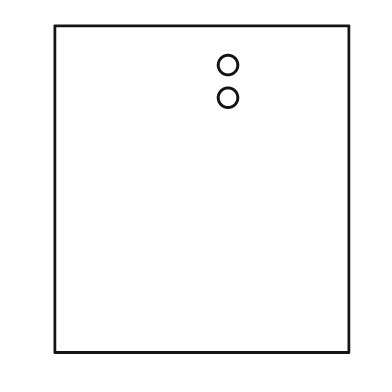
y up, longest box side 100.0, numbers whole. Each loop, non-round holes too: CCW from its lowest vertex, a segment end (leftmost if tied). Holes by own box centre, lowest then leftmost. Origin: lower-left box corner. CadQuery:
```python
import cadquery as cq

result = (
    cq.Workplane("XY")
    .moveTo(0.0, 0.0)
    .lineTo(90.0, 0.0)
    .lineTo(90.0, 100.0)
    .lineTo(0.0, 100.0)
    .close()
    .moveTo(53.0, 78.0)
    .circle(3.0)
    .moveTo(53.0, 88.0)
    .circle(3.0)
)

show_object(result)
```